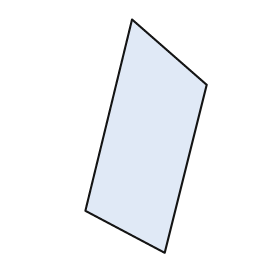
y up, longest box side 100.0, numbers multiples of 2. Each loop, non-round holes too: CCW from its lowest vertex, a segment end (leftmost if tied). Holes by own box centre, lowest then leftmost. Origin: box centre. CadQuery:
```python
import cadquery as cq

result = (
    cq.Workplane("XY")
    .moveTo(8.0, -50.0)
    .lineTo(26.0, 22.0)
    .lineTo(-6.0, 50.0)
    .lineTo(-26.0, -32.0)
    .close()
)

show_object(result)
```